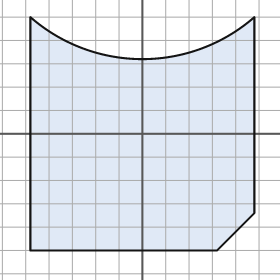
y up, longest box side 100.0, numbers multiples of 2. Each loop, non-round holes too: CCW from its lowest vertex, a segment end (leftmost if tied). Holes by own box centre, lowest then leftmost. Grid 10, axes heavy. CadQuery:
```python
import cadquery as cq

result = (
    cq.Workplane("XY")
    .moveTo(-48.0, -50.0)
    .lineTo(32.0, -50.0)
    .lineTo(48.0, -34.0)
    .lineTo(48.0, 50.0)
    .threePointArc((0.0, 32.0), (-48.0, 50.0))
    .close()
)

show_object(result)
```